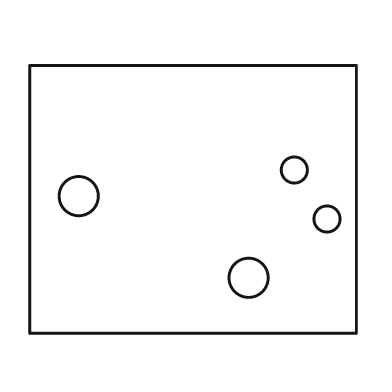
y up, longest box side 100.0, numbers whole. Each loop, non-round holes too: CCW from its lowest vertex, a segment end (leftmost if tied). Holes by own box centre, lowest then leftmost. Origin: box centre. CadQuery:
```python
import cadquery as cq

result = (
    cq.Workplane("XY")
    .moveTo(-50.0, -41.0)
    .lineTo(50.0, -41.0)
    .lineTo(50.0, 41.0)
    .lineTo(-50.0, 41.0)
    .close()
    .moveTo(17.0, -24.0)
    .circle(6.0)
    .moveTo(41.0, -6.0)
    .circle(4.0)
    .moveTo(-35.0, 1.0)
    .circle(6.0)
    .moveTo(31.0, 9.0)
    .circle(4.0)
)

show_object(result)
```